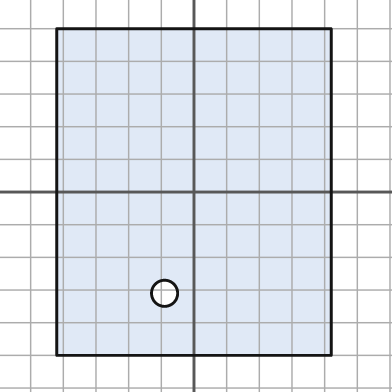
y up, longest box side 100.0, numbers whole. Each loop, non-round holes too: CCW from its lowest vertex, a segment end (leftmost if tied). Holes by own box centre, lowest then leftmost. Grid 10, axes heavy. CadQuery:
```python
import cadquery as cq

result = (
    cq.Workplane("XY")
    .moveTo(-42.0, -50.0)
    .lineTo(42.0, -50.0)
    .lineTo(42.0, 50.0)
    .lineTo(-42.0, 50.0)
    .close()
    .moveTo(-9.0, -31.0)
    .circle(4.0)
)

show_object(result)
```